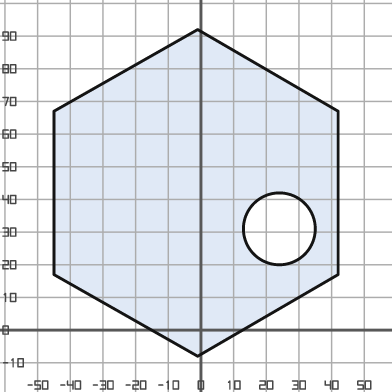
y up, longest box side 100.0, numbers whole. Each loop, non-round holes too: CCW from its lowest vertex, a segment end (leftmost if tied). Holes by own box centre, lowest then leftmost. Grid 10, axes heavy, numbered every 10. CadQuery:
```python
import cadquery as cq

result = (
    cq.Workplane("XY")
    .moveTo(-1.0, -8.0)
    .lineTo(42.0, 17.0)
    .lineTo(42.0, 67.0)
    .lineTo(-1.0, 92.0)
    .lineTo(-45.0, 67.0)
    .lineTo(-45.0, 17.0)
    .close()
    .moveTo(24.0, 31.0)
    .circle(11.0)
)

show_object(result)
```